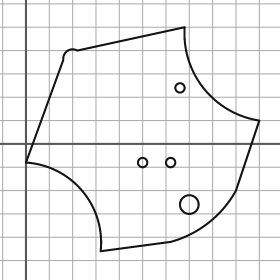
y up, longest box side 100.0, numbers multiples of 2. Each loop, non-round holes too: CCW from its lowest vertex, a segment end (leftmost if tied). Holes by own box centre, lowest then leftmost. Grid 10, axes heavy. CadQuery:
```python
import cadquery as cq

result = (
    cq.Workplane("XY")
    .moveTo(32.0, -46.0)
    .lineTo(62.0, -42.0)
    .threePointArc((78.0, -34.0), (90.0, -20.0))
    .lineTo(100.0, 10.0)
    .threePointArc((76.0, 24.0), (68.0, 50.0))
    .lineTo(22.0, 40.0)
    .threePointArc((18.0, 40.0), (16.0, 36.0))
    .lineTo(0.0, -8.0)
    .threePointArc((24.0, -20.0), (32.0, -46.0))
    .close()
    .moveTo(70.0, -26.0)
    .circle(4.0)
    .moveTo(50.0, -8.0)
    .circle(2.0)
    .moveTo(62.0, -8.0)
    .circle(2.0)
    .moveTo(66.0, 24.0)
    .circle(2.0)
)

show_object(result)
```